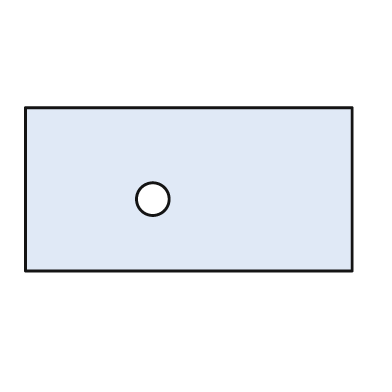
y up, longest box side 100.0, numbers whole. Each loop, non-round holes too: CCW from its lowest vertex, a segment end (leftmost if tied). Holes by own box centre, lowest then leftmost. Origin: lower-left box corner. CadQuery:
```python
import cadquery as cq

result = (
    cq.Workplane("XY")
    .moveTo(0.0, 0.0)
    .lineTo(100.0, 0.0)
    .lineTo(100.0, 50.0)
    .lineTo(0.0, 50.0)
    .close()
    .moveTo(39.0, 22.0)
    .circle(5.0)
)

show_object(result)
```